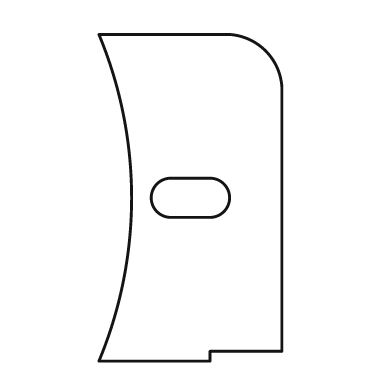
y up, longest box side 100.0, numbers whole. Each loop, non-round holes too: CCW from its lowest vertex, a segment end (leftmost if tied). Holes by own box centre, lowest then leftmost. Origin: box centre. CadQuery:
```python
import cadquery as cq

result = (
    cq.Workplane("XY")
    .moveTo(-28.0, -50.0)
    .lineTo(6.0, -50.0)
    .lineTo(6.0, -47.0)
    .lineTo(28.0, -47.0)
    .lineTo(28.0, 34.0)
    .threePointArc((23.0, 45.0), (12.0, 50.0))
    .lineTo(-28.0, 50.0)
    .threePointArc((-18.0, 0.0), (-28.0, -50.0))
    .close()
    .moveTo(-6.0, -6.0)
    .lineTo(6.0, -6.0)
    .threePointArc((12.0, 0.0), (6.0, 6.0))
    .lineTo(-6.0, 6.0)
    .threePointArc((-12.0, 0.0), (-6.0, -6.0))
    .close()
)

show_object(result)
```